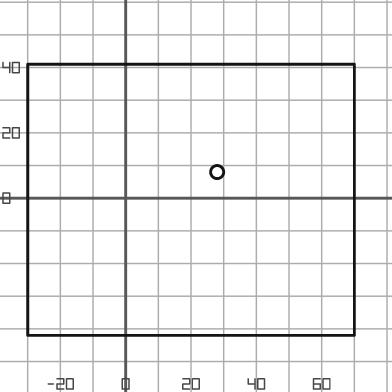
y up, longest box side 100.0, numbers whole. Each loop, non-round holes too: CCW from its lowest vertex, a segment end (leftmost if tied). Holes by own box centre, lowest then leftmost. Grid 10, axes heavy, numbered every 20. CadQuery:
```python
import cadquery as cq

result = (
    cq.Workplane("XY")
    .moveTo(-30.0, -42.0)
    .lineTo(70.0, -42.0)
    .lineTo(70.0, 41.0)
    .lineTo(-30.0, 41.0)
    .close()
    .moveTo(28.0, 8.0)
    .circle(2.0)
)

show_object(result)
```